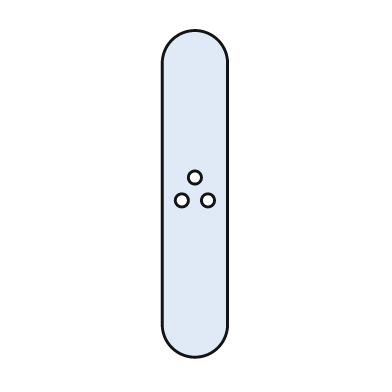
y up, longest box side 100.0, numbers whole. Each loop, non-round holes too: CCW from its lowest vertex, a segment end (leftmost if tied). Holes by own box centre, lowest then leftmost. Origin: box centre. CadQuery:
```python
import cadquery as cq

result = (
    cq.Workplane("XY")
    .moveTo(-10.0, -40.0)
    .threePointArc((0.0, -50.0), (10.0, -40.0))
    .lineTo(10.0, 40.0)
    .threePointArc((0.0, 50.0), (-10.0, 40.0))
    .close()
    .moveTo(-4.0, -2.0)
    .circle(2.0)
    .moveTo(4.0, -2.0)
    .circle(2.0)
    .moveTo(0.0, 5.0)
    .circle(2.0)
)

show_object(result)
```